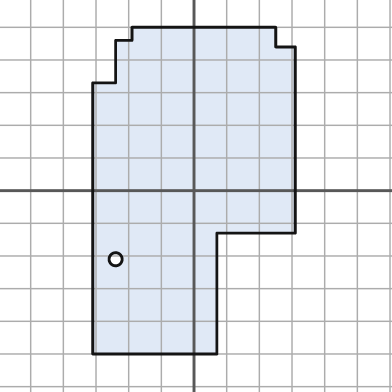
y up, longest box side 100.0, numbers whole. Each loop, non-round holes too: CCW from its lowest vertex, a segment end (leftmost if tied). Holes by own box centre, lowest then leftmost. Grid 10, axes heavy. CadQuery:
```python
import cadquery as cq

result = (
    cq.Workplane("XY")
    .moveTo(-31.0, -50.0)
    .lineTo(7.0, -50.0)
    .lineTo(7.0, -13.0)
    .lineTo(31.0, -13.0)
    .lineTo(31.0, 44.0)
    .lineTo(25.0, 44.0)
    .lineTo(25.0, 50.0)
    .lineTo(-19.0, 50.0)
    .lineTo(-19.0, 46.0)
    .lineTo(-24.0, 46.0)
    .lineTo(-24.0, 33.0)
    .lineTo(-31.0, 33.0)
    .close()
    .moveTo(-24.0, -21.0)
    .circle(2.0)
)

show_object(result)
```